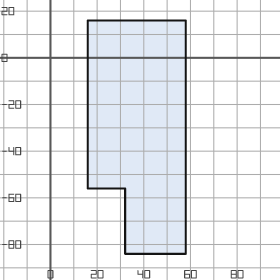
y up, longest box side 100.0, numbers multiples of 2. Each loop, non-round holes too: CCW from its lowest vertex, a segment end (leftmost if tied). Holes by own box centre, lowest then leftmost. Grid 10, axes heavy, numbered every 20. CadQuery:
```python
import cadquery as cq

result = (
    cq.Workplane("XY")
    .moveTo(32.0, -84.0)
    .lineTo(58.0, -84.0)
    .lineTo(58.0, 16.0)
    .lineTo(16.0, 16.0)
    .lineTo(16.0, -56.0)
    .lineTo(32.0, -56.0)
    .close()
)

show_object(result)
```